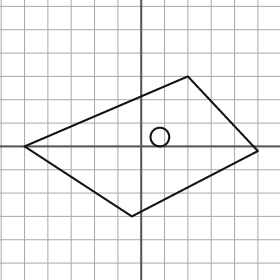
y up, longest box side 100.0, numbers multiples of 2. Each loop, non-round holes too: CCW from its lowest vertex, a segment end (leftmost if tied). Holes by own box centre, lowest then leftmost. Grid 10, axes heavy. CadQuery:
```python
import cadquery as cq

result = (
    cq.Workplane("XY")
    .moveTo(-4.0, -30.0)
    .lineTo(50.0, -2.0)
    .lineTo(20.0, 30.0)
    .lineTo(-50.0, 0.0)
    .close()
    .moveTo(8.0, 4.0)
    .circle(4.0)
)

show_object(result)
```